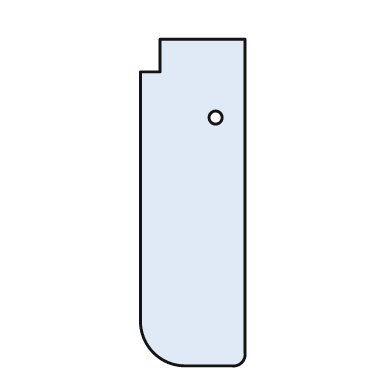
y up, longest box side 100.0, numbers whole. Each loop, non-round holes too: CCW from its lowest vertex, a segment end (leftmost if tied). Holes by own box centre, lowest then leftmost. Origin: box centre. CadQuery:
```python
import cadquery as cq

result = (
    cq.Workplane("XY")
    .moveTo(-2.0, -50.0)
    .lineTo(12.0, -50.0)
    .threePointArc((15.0, -49.0), (16.0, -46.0))
    .lineTo(16.0, 50.0)
    .lineTo(-10.0, 50.0)
    .lineTo(-10.0, 40.0)
    .lineTo(-16.0, 40.0)
    .lineTo(-16.0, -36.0)
    .threePointArc((-12.0, -46.0), (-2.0, -50.0))
    .close()
    .moveTo(7.0, 26.0)
    .circle(2.0)
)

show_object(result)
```